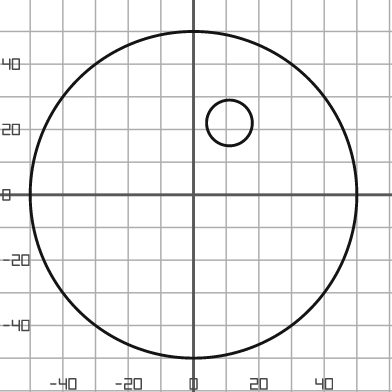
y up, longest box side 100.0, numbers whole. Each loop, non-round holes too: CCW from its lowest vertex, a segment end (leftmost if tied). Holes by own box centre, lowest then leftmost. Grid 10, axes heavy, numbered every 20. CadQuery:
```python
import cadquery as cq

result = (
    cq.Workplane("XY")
    .moveTo(0.0, 0.0)
    .circle(50.0)
    .moveTo(11.0, 22.0)
    .circle(7.0)
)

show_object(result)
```